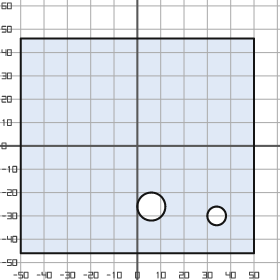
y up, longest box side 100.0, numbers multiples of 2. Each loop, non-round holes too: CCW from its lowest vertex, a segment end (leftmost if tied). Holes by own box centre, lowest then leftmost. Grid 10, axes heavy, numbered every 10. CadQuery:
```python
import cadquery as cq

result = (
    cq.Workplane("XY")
    .moveTo(-50.0, -46.0)
    .lineTo(50.0, -46.0)
    .lineTo(50.0, 46.0)
    .lineTo(-50.0, 46.0)
    .close()
    .moveTo(34.0, -30.0)
    .circle(4.0)
    .moveTo(6.0, -26.0)
    .circle(6.0)
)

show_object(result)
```